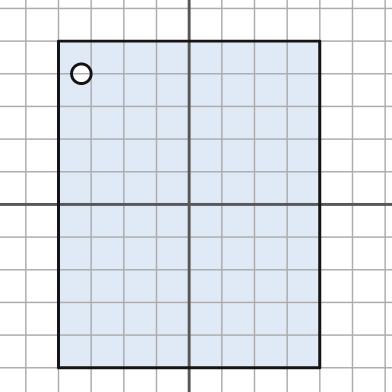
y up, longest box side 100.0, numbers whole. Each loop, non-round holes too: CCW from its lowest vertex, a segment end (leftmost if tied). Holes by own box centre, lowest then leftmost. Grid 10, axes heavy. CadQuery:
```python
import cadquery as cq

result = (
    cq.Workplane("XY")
    .moveTo(-40.0, -50.0)
    .lineTo(40.0, -50.0)
    .lineTo(40.0, 50.0)
    .lineTo(-40.0, 50.0)
    .close()
    .moveTo(-33.0, 40.0)
    .circle(3.0)
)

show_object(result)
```